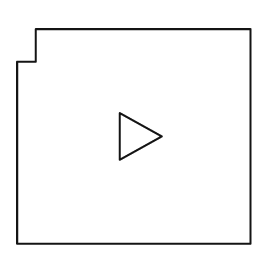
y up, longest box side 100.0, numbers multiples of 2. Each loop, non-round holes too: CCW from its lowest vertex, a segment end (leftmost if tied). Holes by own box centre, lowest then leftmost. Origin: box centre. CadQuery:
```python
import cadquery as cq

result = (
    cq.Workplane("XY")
    .moveTo(-50.0, -46.0)
    .lineTo(50.0, -46.0)
    .lineTo(50.0, 46.0)
    .lineTo(-42.0, 46.0)
    .lineTo(-42.0, 32.0)
    .lineTo(-50.0, 32.0)
    .close()
    .moveTo(-6.0, -10.0)
    .lineTo(12.0, 0.0)
    .lineTo(-6.0, 10.0)
    .close()
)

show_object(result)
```